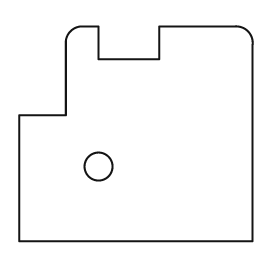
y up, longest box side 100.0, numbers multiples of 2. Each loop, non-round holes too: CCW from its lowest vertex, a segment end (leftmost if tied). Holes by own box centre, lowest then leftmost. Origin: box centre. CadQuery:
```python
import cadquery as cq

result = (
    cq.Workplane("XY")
    .moveTo(-50.0, -46.0)
    .lineTo(50.0, -46.0)
    .lineTo(50.0, 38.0)
    .threePointArc((48.0, 44.0), (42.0, 46.0))
    .lineTo(10.0, 46.0)
    .lineTo(10.0, 32.0)
    .lineTo(-16.0, 32.0)
    .lineTo(-16.0, 46.0)
    .lineTo(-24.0, 46.0)
    .threePointArc((-28.0, 44.0), (-30.0, 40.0))
    .lineTo(-30.0, 8.0)
    .lineTo(-50.0, 8.0)
    .close()
    .moveTo(-16.0, -14.0)
    .circle(6.0)
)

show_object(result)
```